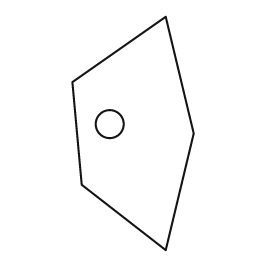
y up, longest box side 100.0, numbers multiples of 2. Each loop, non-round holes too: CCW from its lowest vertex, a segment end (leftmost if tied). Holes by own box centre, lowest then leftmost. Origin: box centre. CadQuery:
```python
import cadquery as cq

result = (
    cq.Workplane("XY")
    .moveTo(14.0, -50.0)
    .lineTo(26.0, 0.0)
    .lineTo(14.0, 50.0)
    .lineTo(-26.0, 22.0)
    .lineTo(-22.0, -22.0)
    .close()
    .moveTo(-10.0, 4.0)
    .circle(6.0)
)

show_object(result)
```